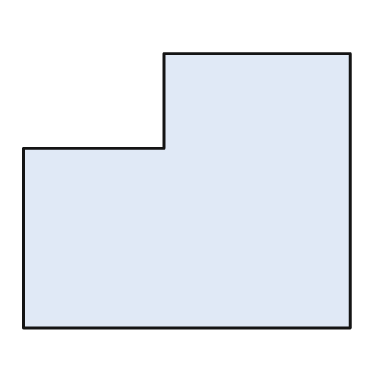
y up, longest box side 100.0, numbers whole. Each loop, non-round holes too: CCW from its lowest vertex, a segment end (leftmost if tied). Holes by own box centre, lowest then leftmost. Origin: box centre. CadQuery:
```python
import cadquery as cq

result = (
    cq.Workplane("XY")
    .moveTo(-50.0, -42.0)
    .lineTo(50.0, -42.0)
    .lineTo(50.0, 42.0)
    .lineTo(-7.0, 42.0)
    .lineTo(-7.0, 13.0)
    .lineTo(-50.0, 13.0)
    .close()
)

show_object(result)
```